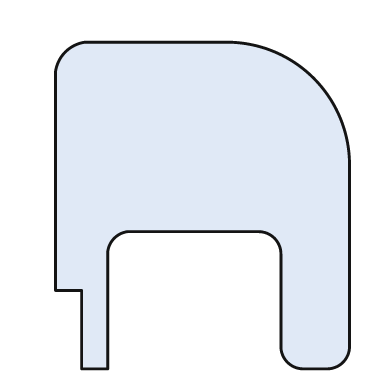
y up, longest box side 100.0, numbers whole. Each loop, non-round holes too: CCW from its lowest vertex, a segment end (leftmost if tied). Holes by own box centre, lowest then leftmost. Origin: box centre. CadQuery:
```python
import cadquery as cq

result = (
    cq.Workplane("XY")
    .moveTo(-37.0, -50.0)
    .lineTo(-29.0, -50.0)
    .lineTo(-29.0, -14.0)
    .threePointArc((-27.0, -10.0), (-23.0, -8.0))
    .lineTo(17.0, -8.0)
    .threePointArc((22.0, -10.0), (24.0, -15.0))
    .lineTo(24.0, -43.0)
    .threePointArc((26.0, -48.0), (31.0, -50.0))
    .lineTo(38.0, -50.0)
    .threePointArc((43.0, -48.0), (45.0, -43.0))
    .lineTo(45.0, 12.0)
    .threePointArc((34.0, 39.0), (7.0, 50.0))
    .lineTo(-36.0, 50.0)
    .threePointArc((-42.0, 47.0), (-45.0, 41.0))
    .lineTo(-45.0, -26.0)
    .lineTo(-37.0, -26.0)
    .close()
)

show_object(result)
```